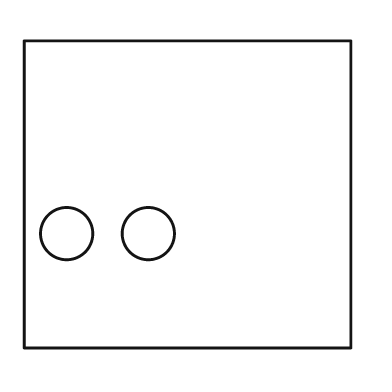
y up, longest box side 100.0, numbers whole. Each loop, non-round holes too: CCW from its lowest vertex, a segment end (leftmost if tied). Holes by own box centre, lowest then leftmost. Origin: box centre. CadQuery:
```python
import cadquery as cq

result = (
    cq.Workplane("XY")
    .moveTo(-50.0, -47.0)
    .lineTo(50.0, -47.0)
    .lineTo(50.0, 47.0)
    .lineTo(-50.0, 47.0)
    .close()
    .moveTo(-37.0, -12.0)
    .circle(8.0)
    .moveTo(-12.0, -12.0)
    .circle(8.0)
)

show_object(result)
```